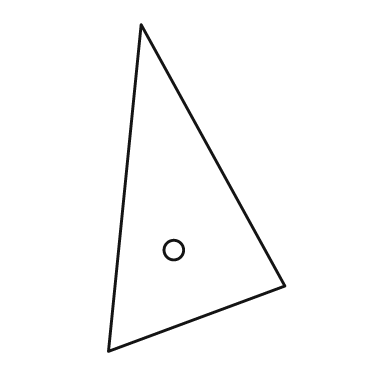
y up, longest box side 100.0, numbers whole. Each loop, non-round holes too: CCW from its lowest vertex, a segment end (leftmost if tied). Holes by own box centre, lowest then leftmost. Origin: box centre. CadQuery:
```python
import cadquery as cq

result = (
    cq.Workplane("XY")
    .moveTo(-27.0, -50.0)
    .lineTo(27.0, -30.0)
    .lineTo(-17.0, 50.0)
    .close()
    .moveTo(-7.0, -19.0)
    .circle(3.0)
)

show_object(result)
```